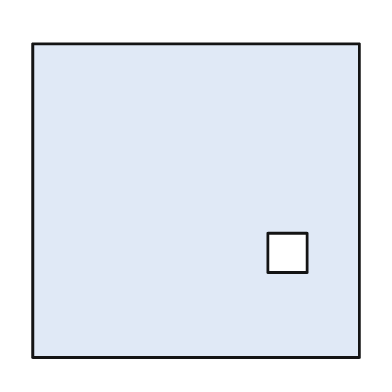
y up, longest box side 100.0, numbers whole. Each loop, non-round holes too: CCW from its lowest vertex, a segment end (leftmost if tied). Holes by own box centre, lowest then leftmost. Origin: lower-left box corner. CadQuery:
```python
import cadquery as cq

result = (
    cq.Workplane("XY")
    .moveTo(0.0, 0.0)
    .lineTo(100.0, 0.0)
    .lineTo(100.0, 96.0)
    .lineTo(0.0, 96.0)
    .close()
    .moveTo(72.0, 26.0)
    .lineTo(84.0, 26.0)
    .lineTo(84.0, 38.0)
    .lineTo(72.0, 38.0)
    .close()
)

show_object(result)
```